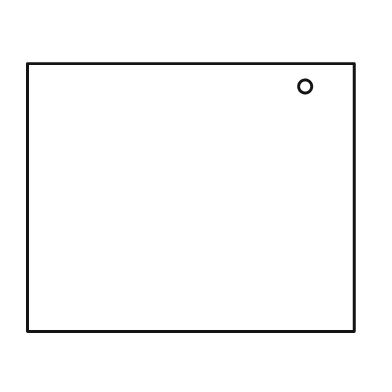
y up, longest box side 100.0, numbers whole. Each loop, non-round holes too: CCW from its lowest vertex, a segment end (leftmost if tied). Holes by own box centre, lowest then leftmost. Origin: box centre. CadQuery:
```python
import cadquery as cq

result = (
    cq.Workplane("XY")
    .moveTo(-50.0, -41.0)
    .lineTo(50.0, -41.0)
    .lineTo(50.0, 41.0)
    .lineTo(-50.0, 41.0)
    .close()
    .moveTo(35.0, 34.0)
    .circle(2.0)
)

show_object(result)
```